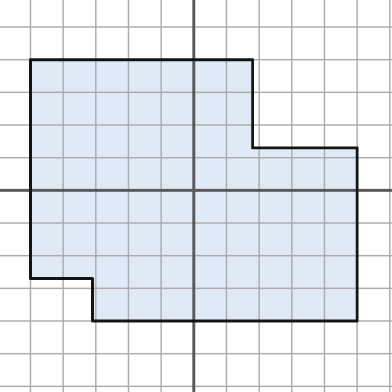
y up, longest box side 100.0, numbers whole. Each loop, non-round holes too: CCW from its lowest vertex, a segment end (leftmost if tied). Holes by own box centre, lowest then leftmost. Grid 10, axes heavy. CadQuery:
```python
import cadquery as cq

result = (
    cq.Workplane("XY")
    .moveTo(-31.0, -40.0)
    .lineTo(50.0, -40.0)
    .lineTo(50.0, 13.0)
    .lineTo(18.0, 13.0)
    .lineTo(18.0, 40.0)
    .lineTo(-50.0, 40.0)
    .lineTo(-50.0, -27.0)
    .lineTo(-31.0, -27.0)
    .close()
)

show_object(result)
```